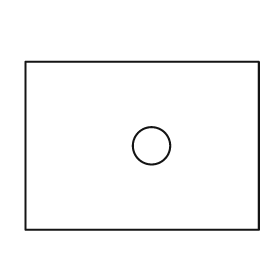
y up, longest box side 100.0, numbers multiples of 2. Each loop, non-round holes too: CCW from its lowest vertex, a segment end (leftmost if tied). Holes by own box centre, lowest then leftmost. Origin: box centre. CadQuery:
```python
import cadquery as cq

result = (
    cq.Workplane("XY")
    .moveTo(-50.0, -36.0)
    .lineTo(50.0, -36.0)
    .lineTo(50.0, 36.0)
    .lineTo(-50.0, 36.0)
    .close()
    .moveTo(4.0, 0.0)
    .circle(8.0)
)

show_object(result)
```